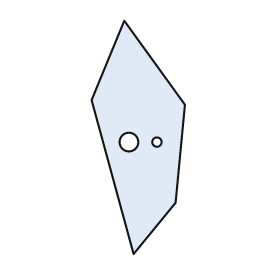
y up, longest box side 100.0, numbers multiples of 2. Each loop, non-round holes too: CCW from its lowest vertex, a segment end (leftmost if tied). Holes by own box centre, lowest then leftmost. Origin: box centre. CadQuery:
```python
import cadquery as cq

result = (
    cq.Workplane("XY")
    .moveTo(-2.0, -50.0)
    .lineTo(16.0, -28.0)
    .lineTo(20.0, 14.0)
    .lineTo(-6.0, 50.0)
    .lineTo(-20.0, 16.0)
    .close()
    .moveTo(-4.0, -2.0)
    .circle(4.0)
    .moveTo(8.0, -2.0)
    .circle(2.0)
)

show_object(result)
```